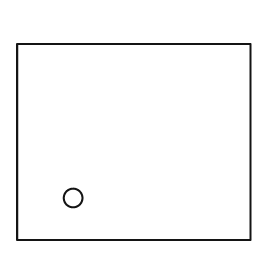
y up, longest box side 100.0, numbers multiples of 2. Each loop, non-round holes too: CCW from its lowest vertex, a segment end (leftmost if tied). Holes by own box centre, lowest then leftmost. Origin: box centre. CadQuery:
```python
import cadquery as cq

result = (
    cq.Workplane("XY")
    .moveTo(-50.0, -42.0)
    .lineTo(50.0, -42.0)
    .lineTo(50.0, 42.0)
    .lineTo(-50.0, 42.0)
    .close()
    .moveTo(-26.0, -24.0)
    .circle(4.0)
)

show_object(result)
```